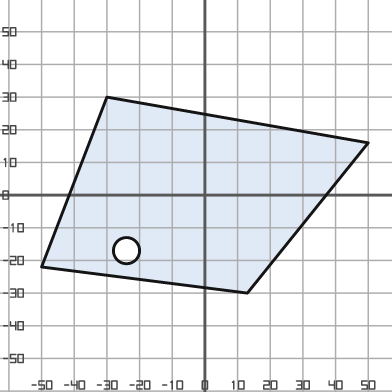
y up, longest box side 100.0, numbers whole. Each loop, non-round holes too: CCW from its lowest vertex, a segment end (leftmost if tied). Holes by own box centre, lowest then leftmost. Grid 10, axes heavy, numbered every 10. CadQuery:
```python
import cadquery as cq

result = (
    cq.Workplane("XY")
    .moveTo(13.0, -30.0)
    .lineTo(50.0, 16.0)
    .lineTo(-30.0, 30.0)
    .lineTo(-50.0, -22.0)
    .close()
    .moveTo(-24.0, -17.0)
    .circle(4.0)
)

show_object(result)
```